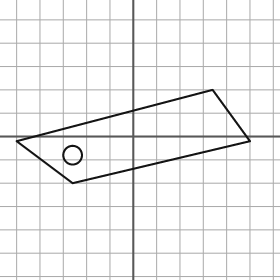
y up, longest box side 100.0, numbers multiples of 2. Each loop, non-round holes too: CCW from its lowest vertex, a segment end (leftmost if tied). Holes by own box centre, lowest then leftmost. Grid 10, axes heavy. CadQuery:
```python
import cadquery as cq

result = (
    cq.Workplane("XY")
    .moveTo(-26.0, -20.0)
    .lineTo(50.0, -2.0)
    .lineTo(34.0, 20.0)
    .lineTo(-50.0, -2.0)
    .close()
    .moveTo(-26.0, -8.0)
    .circle(4.0)
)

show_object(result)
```